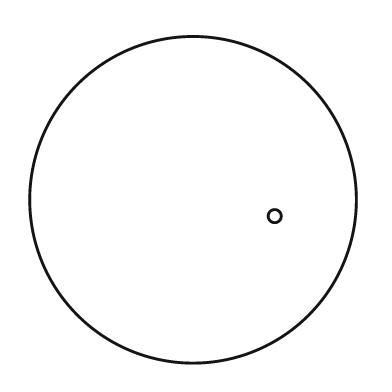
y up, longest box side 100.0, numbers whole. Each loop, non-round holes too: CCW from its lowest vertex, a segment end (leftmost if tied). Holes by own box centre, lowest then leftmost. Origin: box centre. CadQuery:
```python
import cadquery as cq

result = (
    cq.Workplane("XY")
    .moveTo(0.0, 0.0)
    .circle(50.0)
    .moveTo(25.0, -5.0)
    .circle(2.0)
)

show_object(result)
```